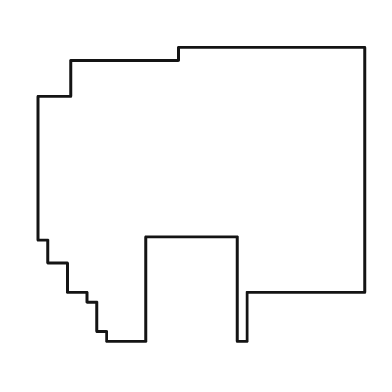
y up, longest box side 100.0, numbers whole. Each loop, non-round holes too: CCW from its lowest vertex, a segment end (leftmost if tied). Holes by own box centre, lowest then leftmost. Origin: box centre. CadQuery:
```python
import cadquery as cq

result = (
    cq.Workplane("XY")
    .moveTo(-29.0, -45.0)
    .lineTo(-17.0, -45.0)
    .lineTo(-17.0, -13.0)
    .lineTo(11.0, -13.0)
    .lineTo(11.0, -45.0)
    .lineTo(14.0, -45.0)
    .lineTo(14.0, -30.0)
    .lineTo(50.0, -30.0)
    .lineTo(50.0, 45.0)
    .lineTo(-7.0, 45.0)
    .lineTo(-7.0, 41.0)
    .lineTo(-40.0, 41.0)
    .lineTo(-40.0, 30.0)
    .lineTo(-50.0, 30.0)
    .lineTo(-50.0, -14.0)
    .lineTo(-47.0, -14.0)
    .lineTo(-47.0, -21.0)
    .lineTo(-41.0, -21.0)
    .lineTo(-41.0, -30.0)
    .lineTo(-35.0, -30.0)
    .lineTo(-35.0, -33.0)
    .lineTo(-32.0, -33.0)
    .lineTo(-32.0, -42.0)
    .lineTo(-29.0, -42.0)
    .close()
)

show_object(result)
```